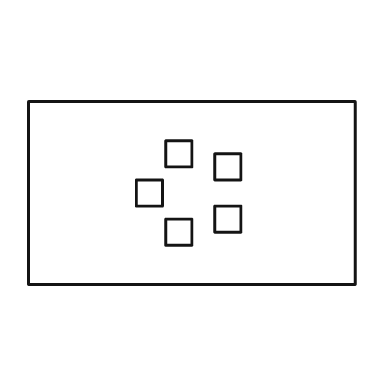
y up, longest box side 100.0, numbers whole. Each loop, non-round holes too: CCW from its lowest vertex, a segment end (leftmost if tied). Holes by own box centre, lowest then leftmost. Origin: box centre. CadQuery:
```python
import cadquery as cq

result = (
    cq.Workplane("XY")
    .moveTo(-50.0, -28.0)
    .lineTo(50.0, -28.0)
    .lineTo(50.0, 28.0)
    .lineTo(-50.0, 28.0)
    .close()
    .moveTo(-8.0, -16.0)
    .lineTo(0.0, -16.0)
    .lineTo(0.0, -8.0)
    .lineTo(-8.0, -8.0)
    .close()
    .moveTo(7.0, -12.0)
    .lineTo(15.0, -12.0)
    .lineTo(15.0, -4.0)
    .lineTo(7.0, -4.0)
    .close()
    .moveTo(-17.0, -4.0)
    .lineTo(-9.0, -4.0)
    .lineTo(-9.0, 4.0)
    .lineTo(-17.0, 4.0)
    .close()
    .moveTo(7.0, 4.0)
    .lineTo(15.0, 4.0)
    .lineTo(15.0, 12.0)
    .lineTo(7.0, 12.0)
    .close()
    .moveTo(-8.0, 8.0)
    .lineTo(0.0, 8.0)
    .lineTo(0.0, 16.0)
    .lineTo(-8.0, 16.0)
    .close()
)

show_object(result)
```